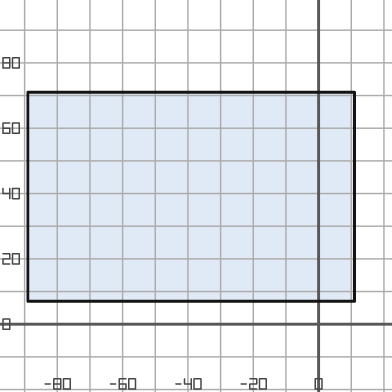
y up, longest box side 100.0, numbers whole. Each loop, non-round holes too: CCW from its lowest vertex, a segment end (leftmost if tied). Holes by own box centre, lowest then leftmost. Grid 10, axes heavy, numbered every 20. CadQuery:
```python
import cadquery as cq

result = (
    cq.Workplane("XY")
    .moveTo(-89.0, 7.0)
    .lineTo(11.0, 7.0)
    .lineTo(11.0, 71.0)
    .lineTo(-89.0, 71.0)
    .close()
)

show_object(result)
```